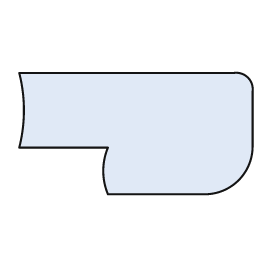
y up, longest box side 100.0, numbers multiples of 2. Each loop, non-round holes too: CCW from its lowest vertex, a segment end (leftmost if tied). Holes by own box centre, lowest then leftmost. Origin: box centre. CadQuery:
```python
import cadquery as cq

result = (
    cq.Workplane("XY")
    .moveTo(-12.0, -26.0)
    .lineTo(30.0, -26.0)
    .threePointArc((44.0, -20.0), (50.0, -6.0))
    .lineTo(50.0, 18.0)
    .threePointArc((48.0, 24.0), (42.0, 26.0))
    .lineTo(-50.0, 26.0)
    .threePointArc((-48.0, 10.0), (-50.0, -6.0))
    .lineTo(-12.0, -6.0)
    .threePointArc((-14.0, -16.0), (-12.0, -26.0))
    .close()
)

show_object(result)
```